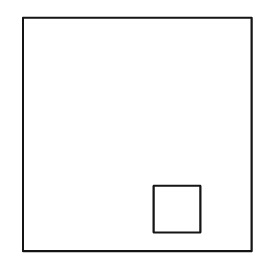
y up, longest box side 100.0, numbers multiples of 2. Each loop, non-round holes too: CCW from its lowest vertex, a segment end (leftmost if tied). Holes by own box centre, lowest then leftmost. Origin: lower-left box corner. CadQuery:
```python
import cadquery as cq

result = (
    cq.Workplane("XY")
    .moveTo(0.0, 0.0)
    .lineTo(98.0, 0.0)
    .lineTo(98.0, 100.0)
    .lineTo(0.0, 100.0)
    .close()
    .moveTo(56.0, 8.0)
    .lineTo(76.0, 8.0)
    .lineTo(76.0, 28.0)
    .lineTo(56.0, 28.0)
    .close()
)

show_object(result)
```